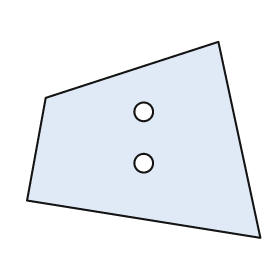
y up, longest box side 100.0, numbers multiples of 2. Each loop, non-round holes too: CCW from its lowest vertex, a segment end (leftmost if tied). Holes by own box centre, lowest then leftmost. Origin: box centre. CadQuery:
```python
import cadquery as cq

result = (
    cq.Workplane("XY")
    .moveTo(50.0, -42.0)
    .lineTo(32.0, 42.0)
    .lineTo(-42.0, 18.0)
    .lineTo(-50.0, -26.0)
    .close()
    .moveTo(0.0, -10.0)
    .circle(4.0)
    .moveTo(0.0, 12.0)
    .circle(4.0)
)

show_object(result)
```